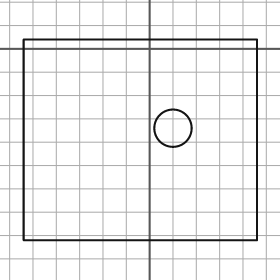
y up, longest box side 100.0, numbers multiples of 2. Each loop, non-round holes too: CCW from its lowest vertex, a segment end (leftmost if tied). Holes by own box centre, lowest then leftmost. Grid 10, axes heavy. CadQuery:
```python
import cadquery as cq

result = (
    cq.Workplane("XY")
    .moveTo(-54.0, -82.0)
    .lineTo(46.0, -82.0)
    .lineTo(46.0, 4.0)
    .lineTo(-54.0, 4.0)
    .close()
    .moveTo(10.0, -34.0)
    .circle(8.0)
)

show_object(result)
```